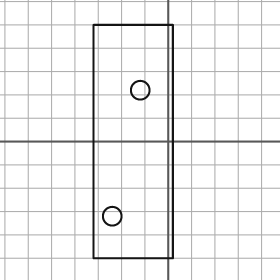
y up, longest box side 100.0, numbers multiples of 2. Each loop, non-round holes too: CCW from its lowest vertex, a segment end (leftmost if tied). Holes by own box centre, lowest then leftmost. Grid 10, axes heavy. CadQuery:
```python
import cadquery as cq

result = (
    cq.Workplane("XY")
    .moveTo(-32.0, -50.0)
    .lineTo(2.0, -50.0)
    .lineTo(2.0, 50.0)
    .lineTo(-32.0, 50.0)
    .close()
    .moveTo(-24.0, -32.0)
    .circle(4.0)
    .moveTo(-12.0, 22.0)
    .circle(4.0)
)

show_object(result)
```